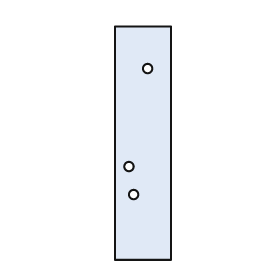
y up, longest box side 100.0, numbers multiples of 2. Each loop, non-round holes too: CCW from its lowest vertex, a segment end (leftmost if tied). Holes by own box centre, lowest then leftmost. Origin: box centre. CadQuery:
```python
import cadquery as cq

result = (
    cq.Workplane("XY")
    .moveTo(-12.0, -50.0)
    .lineTo(12.0, -50.0)
    .lineTo(12.0, 50.0)
    .lineTo(-12.0, 50.0)
    .close()
    .moveTo(-4.0, -22.0)
    .circle(2.0)
    .moveTo(-6.0, -10.0)
    .circle(2.0)
    .moveTo(2.0, 32.0)
    .circle(2.0)
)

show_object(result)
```